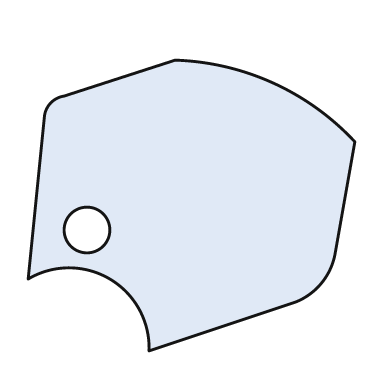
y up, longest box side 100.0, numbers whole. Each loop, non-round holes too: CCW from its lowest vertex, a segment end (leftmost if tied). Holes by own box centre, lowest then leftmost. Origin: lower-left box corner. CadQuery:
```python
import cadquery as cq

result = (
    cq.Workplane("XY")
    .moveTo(37.0, 0.0)
    .lineTo(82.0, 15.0)
    .threePointArc((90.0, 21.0), (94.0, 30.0))
    .lineTo(100.0, 64.0)
    .threePointArc((75.0, 82.0), (45.0, 89.0))
    .lineTo(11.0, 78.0)
    .threePointArc((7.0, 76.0), (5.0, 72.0))
    .lineTo(0.0, 22.0)
    .threePointArc((25.0, 22.0), (37.0, 0.0))
    .close()
    .moveTo(18.0, 37.0)
    .circle(7.0)
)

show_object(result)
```